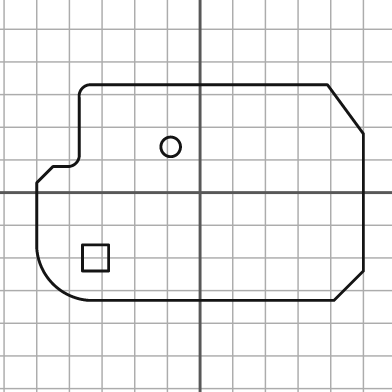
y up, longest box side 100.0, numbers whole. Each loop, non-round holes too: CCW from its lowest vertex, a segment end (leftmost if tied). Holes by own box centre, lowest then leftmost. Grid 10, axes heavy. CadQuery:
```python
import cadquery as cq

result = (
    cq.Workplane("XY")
    .moveTo(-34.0, -33.0)
    .lineTo(41.0, -33.0)
    .lineTo(50.0, -24.0)
    .lineTo(50.0, 18.0)
    .lineTo(39.0, 33.0)
    .lineTo(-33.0, 33.0)
    .threePointArc((-36.0, 32.0), (-37.0, 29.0))
    .lineTo(-37.0, 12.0)
    .threePointArc((-38.0, 9.0), (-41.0, 8.0))
    .lineTo(-45.0, 8.0)
    .lineTo(-50.0, 3.0)
    .lineTo(-50.0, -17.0)
    .threePointArc((-45.0, -28.0), (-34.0, -33.0))
    .close()
    .moveTo(-36.0, -24.0)
    .lineTo(-28.0, -24.0)
    .lineTo(-28.0, -16.0)
    .lineTo(-36.0, -16.0)
    .close()
    .moveTo(-9.0, 14.0)
    .circle(3.0)
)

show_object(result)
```